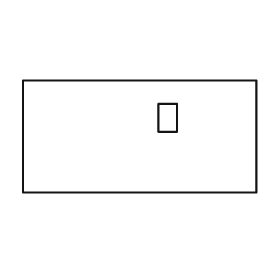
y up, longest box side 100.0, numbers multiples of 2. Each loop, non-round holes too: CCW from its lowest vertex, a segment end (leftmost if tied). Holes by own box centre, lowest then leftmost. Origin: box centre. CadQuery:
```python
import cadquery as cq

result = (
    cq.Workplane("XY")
    .moveTo(-50.0, -24.0)
    .lineTo(50.0, -24.0)
    .lineTo(50.0, 24.0)
    .lineTo(-50.0, 24.0)
    .close()
    .moveTo(8.0, 2.0)
    .lineTo(16.0, 2.0)
    .lineTo(16.0, 14.0)
    .lineTo(8.0, 14.0)
    .close()
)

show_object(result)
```